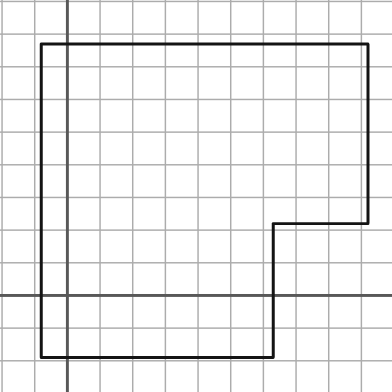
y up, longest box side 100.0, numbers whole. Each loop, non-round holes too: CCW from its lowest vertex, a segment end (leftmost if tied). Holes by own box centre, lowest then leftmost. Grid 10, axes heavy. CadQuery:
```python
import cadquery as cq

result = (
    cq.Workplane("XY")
    .moveTo(-8.0, -19.0)
    .lineTo(63.0, -19.0)
    .lineTo(63.0, 22.0)
    .lineTo(92.0, 22.0)
    .lineTo(92.0, 77.0)
    .lineTo(-8.0, 77.0)
    .close()
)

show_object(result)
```